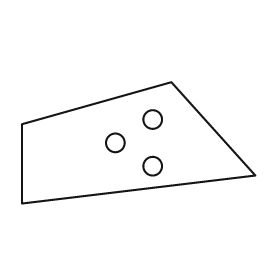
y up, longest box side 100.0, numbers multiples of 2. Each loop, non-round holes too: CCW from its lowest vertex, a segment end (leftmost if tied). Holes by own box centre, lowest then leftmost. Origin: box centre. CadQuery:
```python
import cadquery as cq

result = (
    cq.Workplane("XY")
    .moveTo(-50.0, -26.0)
    .lineTo(50.0, -14.0)
    .lineTo(14.0, 26.0)
    .lineTo(-50.0, 8.0)
    .close()
    .moveTo(6.0, -10.0)
    .circle(4.0)
    .moveTo(-10.0, 0.0)
    .circle(4.0)
    .moveTo(6.0, 10.0)
    .circle(4.0)
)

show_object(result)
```